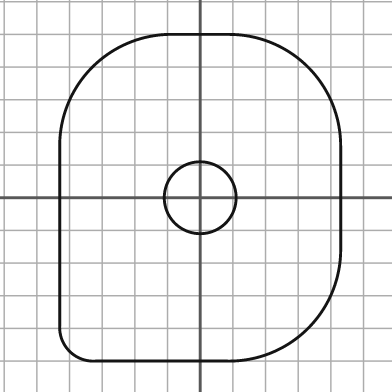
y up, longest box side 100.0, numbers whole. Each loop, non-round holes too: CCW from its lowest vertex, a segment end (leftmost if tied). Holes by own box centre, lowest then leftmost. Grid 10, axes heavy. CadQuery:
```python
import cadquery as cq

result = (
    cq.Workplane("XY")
    .moveTo(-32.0, -50.0)
    .lineTo(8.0, -50.0)
    .threePointArc((33.0, -40.0), (43.0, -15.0))
    .lineTo(43.0, 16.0)
    .threePointArc((33.0, 40.0), (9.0, 50.0))
    .lineTo(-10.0, 50.0)
    .threePointArc((-33.0, 40.0), (-43.0, 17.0))
    .lineTo(-43.0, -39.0)
    .threePointArc((-40.0, -47.0), (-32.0, -50.0))
    .close()
    .moveTo(0.0, 0.0)
    .circle(11.0)
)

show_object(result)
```